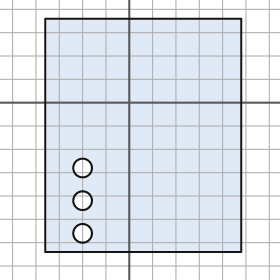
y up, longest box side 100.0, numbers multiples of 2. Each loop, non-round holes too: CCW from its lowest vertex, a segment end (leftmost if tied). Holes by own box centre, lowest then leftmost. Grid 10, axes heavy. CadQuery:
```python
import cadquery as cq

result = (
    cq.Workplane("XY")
    .moveTo(-36.0, -64.0)
    .lineTo(48.0, -64.0)
    .lineTo(48.0, 36.0)
    .lineTo(-36.0, 36.0)
    .close()
    .moveTo(-20.0, -56.0)
    .circle(4.0)
    .moveTo(-20.0, -42.0)
    .circle(4.0)
    .moveTo(-20.0, -28.0)
    .circle(4.0)
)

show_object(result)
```